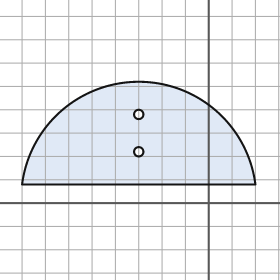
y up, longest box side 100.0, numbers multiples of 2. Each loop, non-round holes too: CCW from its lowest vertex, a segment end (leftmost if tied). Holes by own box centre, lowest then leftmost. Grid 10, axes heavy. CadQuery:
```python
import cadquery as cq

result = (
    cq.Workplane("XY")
    .moveTo(-80.0, 8.0)
    .lineTo(20.0, 8.0)
    .threePointArc((-30.0, 52.0), (-80.0, 8.0))
    .close()
    .moveTo(-30.0, 22.0)
    .circle(2.0)
    .moveTo(-30.0, 38.0)
    .circle(2.0)
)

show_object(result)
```